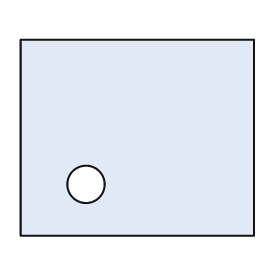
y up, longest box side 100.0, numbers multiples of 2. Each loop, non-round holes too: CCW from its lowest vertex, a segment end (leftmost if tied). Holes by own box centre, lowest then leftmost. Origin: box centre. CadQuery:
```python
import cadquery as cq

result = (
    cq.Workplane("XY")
    .moveTo(-50.0, -42.0)
    .lineTo(50.0, -42.0)
    .lineTo(50.0, 42.0)
    .lineTo(-50.0, 42.0)
    .close()
    .moveTo(-22.0, -20.0)
    .circle(8.0)
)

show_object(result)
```